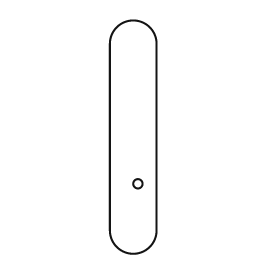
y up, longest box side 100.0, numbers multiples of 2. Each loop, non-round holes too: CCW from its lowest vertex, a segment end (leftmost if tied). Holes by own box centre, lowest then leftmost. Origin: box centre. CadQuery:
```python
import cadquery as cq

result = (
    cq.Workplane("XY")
    .moveTo(-10.0, -40.0)
    .threePointArc((0.0, -50.0), (10.0, -40.0))
    .lineTo(10.0, 40.0)
    .threePointArc((0.0, 50.0), (-10.0, 40.0))
    .close()
    .moveTo(2.0, -20.0)
    .circle(2.0)
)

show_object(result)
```